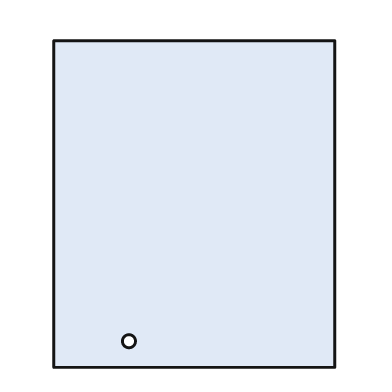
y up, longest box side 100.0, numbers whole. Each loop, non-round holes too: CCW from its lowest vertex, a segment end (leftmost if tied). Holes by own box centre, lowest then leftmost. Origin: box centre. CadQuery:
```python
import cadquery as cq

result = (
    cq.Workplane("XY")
    .moveTo(-43.0, -50.0)
    .lineTo(43.0, -50.0)
    .lineTo(43.0, 50.0)
    .lineTo(-43.0, 50.0)
    .close()
    .moveTo(-20.0, -42.0)
    .circle(2.0)
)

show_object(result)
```